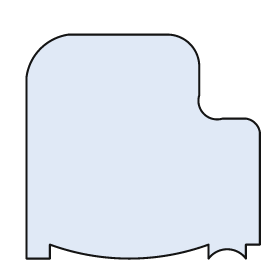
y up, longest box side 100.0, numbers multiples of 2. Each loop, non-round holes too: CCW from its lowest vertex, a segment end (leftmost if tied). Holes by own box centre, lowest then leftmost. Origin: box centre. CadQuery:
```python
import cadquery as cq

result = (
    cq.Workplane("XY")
    .moveTo(-50.0, -48.0)
    .lineTo(-40.0, -48.0)
    .lineTo(-40.0, -42.0)
    .threePointArc((-6.0, -48.0), (28.0, -42.0))
    .lineTo(28.0, -48.0)
    .threePointArc((36.0, -44.0), (44.0, -48.0))
    .lineTo(44.0, -42.0)
    .lineTo(50.0, -42.0)
    .lineTo(50.0, 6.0)
    .threePointArc((48.0, 10.0), (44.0, 12.0))
    .lineTo(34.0, 12.0)
    .threePointArc((26.0, 14.0), (24.0, 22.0))
    .lineTo(24.0, 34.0)
    .threePointArc((20.0, 44.0), (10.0, 48.0))
    .lineTo(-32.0, 48.0)
    .threePointArc((-44.0, 42.0), (-50.0, 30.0))
    .close()
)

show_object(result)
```